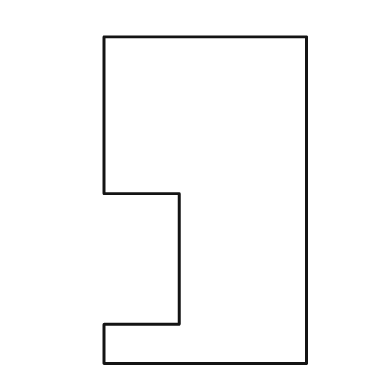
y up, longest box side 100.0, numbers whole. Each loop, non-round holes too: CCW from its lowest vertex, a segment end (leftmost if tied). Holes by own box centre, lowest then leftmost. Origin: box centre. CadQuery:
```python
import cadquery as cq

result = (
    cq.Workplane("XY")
    .moveTo(-31.0, -50.0)
    .lineTo(31.0, -50.0)
    .lineTo(31.0, 50.0)
    .lineTo(-31.0, 50.0)
    .lineTo(-31.0, 2.0)
    .lineTo(-8.0, 2.0)
    .lineTo(-8.0, -38.0)
    .lineTo(-31.0, -38.0)
    .close()
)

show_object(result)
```